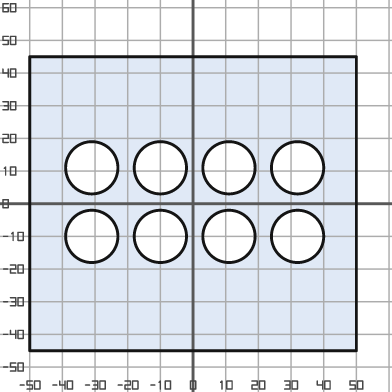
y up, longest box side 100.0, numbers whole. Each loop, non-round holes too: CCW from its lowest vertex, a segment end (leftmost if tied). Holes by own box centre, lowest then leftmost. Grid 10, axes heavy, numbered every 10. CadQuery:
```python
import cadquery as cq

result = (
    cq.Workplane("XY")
    .moveTo(-50.0, -45.0)
    .lineTo(50.0, -45.0)
    .lineTo(50.0, 45.0)
    .lineTo(-50.0, 45.0)
    .close()
    .moveTo(-31.0, -10.0)
    .circle(8.0)
    .moveTo(-10.0, -10.0)
    .circle(8.0)
    .moveTo(11.0, -10.0)
    .circle(8.0)
    .moveTo(32.0, -10.0)
    .circle(8.0)
    .moveTo(-31.0, 11.0)
    .circle(8.0)
    .moveTo(-10.0, 11.0)
    .circle(8.0)
    .moveTo(11.0, 11.0)
    .circle(8.0)
    .moveTo(32.0, 11.0)
    .circle(8.0)
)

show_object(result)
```